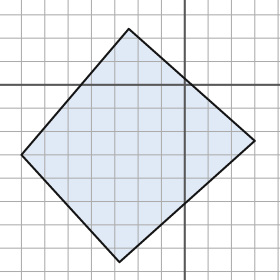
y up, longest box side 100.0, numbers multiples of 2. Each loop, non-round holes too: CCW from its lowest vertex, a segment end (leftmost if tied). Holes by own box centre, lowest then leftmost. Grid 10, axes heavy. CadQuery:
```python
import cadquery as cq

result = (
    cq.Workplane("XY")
    .moveTo(-28.0, -76.0)
    .lineTo(30.0, -24.0)
    .lineTo(-24.0, 24.0)
    .lineTo(-70.0, -30.0)
    .close()
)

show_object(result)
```